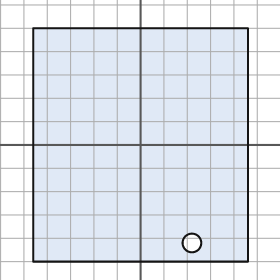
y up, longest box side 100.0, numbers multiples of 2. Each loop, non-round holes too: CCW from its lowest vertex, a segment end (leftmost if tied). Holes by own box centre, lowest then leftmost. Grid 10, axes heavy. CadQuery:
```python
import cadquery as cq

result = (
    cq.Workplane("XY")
    .moveTo(-46.0, -50.0)
    .lineTo(46.0, -50.0)
    .lineTo(46.0, 50.0)
    .lineTo(-46.0, 50.0)
    .close()
    .moveTo(22.0, -42.0)
    .circle(4.0)
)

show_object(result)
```